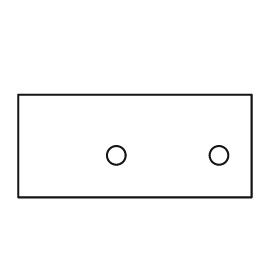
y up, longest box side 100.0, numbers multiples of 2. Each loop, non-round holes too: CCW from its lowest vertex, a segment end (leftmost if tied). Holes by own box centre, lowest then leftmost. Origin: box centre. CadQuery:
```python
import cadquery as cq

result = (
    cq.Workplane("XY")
    .moveTo(-50.0, -22.0)
    .lineTo(50.0, -22.0)
    .lineTo(50.0, 22.0)
    .lineTo(-50.0, 22.0)
    .close()
    .moveTo(-8.0, -4.0)
    .circle(4.0)
    .moveTo(36.0, -4.0)
    .circle(4.0)
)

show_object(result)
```